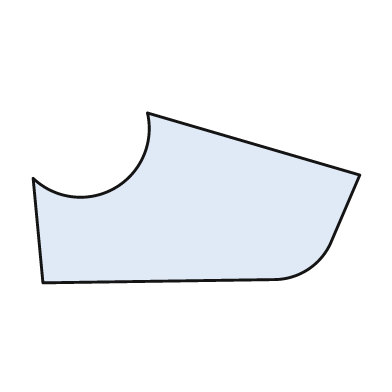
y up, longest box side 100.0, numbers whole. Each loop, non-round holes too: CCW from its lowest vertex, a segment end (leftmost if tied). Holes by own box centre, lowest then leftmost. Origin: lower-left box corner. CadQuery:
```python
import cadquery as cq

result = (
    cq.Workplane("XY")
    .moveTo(3.0, 0.0)
    .lineTo(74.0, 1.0)
    .threePointArc((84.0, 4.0), (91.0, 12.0))
    .lineTo(100.0, 33.0)
    .lineTo(35.0, 52.0)
    .threePointArc((25.0, 29.0), (0.0, 32.0))
    .close()
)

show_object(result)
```